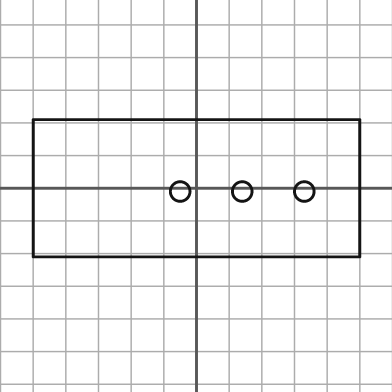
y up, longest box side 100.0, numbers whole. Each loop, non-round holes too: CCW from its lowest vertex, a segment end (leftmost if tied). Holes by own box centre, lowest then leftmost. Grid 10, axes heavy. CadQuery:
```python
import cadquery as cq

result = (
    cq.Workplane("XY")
    .moveTo(-50.0, -21.0)
    .lineTo(50.0, -21.0)
    .lineTo(50.0, 21.0)
    .lineTo(-50.0, 21.0)
    .close()
    .moveTo(-5.0, -1.0)
    .circle(3.0)
    .moveTo(14.0, -1.0)
    .circle(3.0)
    .moveTo(33.0, -1.0)
    .circle(3.0)
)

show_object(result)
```